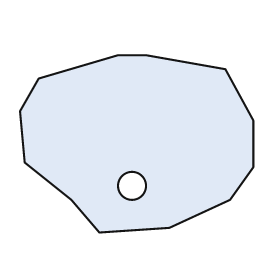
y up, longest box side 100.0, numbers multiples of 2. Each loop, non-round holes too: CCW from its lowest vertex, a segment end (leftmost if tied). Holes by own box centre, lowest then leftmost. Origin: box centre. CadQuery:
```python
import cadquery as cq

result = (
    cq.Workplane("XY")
    .moveTo(-16.0, -38.0)
    .lineTo(14.0, -36.0)
    .lineTo(40.0, -24.0)
    .lineTo(50.0, -10.0)
    .lineTo(50.0, 10.0)
    .lineTo(38.0, 32.0)
    .lineTo(4.0, 38.0)
    .lineTo(-8.0, 38.0)
    .lineTo(-42.0, 28.0)
    .lineTo(-50.0, 14.0)
    .lineTo(-48.0, -8.0)
    .lineTo(-28.0, -24.0)
    .close()
    .moveTo(-2.0, -18.0)
    .circle(6.0)
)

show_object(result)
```